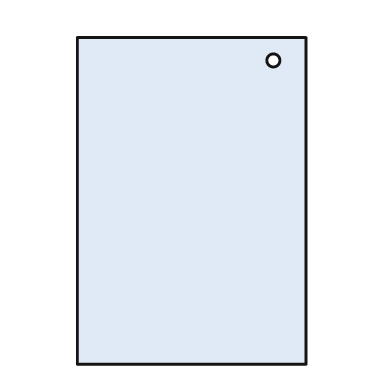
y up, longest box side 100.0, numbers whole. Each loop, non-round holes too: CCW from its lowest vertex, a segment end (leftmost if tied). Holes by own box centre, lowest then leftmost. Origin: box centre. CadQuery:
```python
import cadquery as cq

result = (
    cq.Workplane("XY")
    .moveTo(-35.0, -50.0)
    .lineTo(35.0, -50.0)
    .lineTo(35.0, 50.0)
    .lineTo(-35.0, 50.0)
    .close()
    .moveTo(25.0, 43.0)
    .circle(2.0)
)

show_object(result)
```